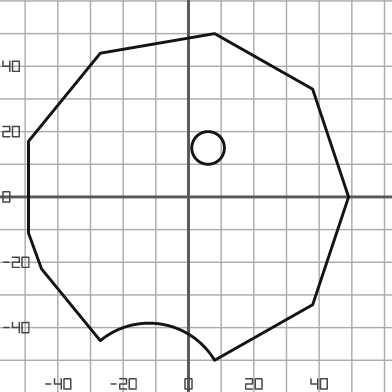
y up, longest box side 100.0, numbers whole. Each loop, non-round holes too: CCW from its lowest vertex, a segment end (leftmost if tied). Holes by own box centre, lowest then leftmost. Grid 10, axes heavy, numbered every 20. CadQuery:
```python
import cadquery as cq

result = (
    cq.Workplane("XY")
    .moveTo(8.0, -50.0)
    .lineTo(38.0, -33.0)
    .lineTo(49.0, 0.0)
    .lineTo(38.0, 33.0)
    .lineTo(8.0, 50.0)
    .lineTo(-27.0, 44.0)
    .lineTo(-49.0, 17.0)
    .lineTo(-49.0, -11.0)
    .lineTo(-45.0, -22.0)
    .lineTo(-27.0, -44.0)
    .threePointArc((-8.0, -39.0), (8.0, -50.0))
    .close()
    .moveTo(6.0, 15.0)
    .circle(5.0)
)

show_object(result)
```